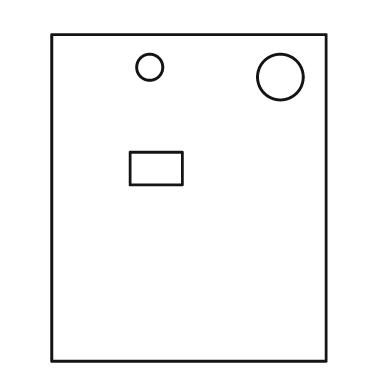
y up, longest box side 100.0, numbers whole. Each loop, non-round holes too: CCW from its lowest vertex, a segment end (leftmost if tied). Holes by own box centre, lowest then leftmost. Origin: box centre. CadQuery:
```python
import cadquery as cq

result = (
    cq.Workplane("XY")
    .moveTo(-42.0, -50.0)
    .lineTo(42.0, -50.0)
    .lineTo(42.0, 50.0)
    .lineTo(-42.0, 50.0)
    .close()
    .moveTo(-18.0, 4.0)
    .lineTo(-2.0, 4.0)
    .lineTo(-2.0, 14.0)
    .lineTo(-18.0, 14.0)
    .close()
    .moveTo(28.0, 37.0)
    .circle(7.0)
    .moveTo(-12.0, 40.0)
    .circle(4.0)
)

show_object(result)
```